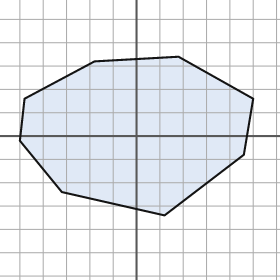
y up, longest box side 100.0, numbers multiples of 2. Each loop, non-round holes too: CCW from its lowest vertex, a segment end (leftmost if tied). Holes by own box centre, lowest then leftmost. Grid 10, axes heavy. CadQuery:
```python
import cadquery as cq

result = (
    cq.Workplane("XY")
    .moveTo(12.0, -34.0)
    .lineTo(46.0, -8.0)
    .lineTo(50.0, 16.0)
    .lineTo(18.0, 34.0)
    .lineTo(-18.0, 32.0)
    .lineTo(-48.0, 16.0)
    .lineTo(-50.0, -2.0)
    .lineTo(-32.0, -24.0)
    .close()
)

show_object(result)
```